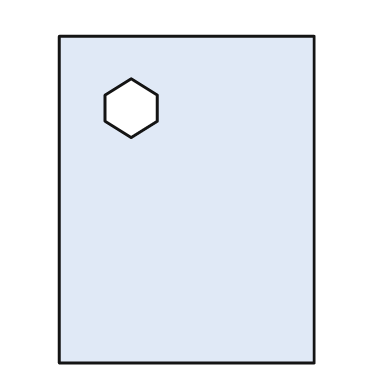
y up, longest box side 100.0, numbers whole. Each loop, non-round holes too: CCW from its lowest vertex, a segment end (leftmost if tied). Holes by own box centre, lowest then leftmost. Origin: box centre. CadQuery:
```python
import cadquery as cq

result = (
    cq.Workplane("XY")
    .moveTo(-39.0, -50.0)
    .lineTo(39.0, -50.0)
    .lineTo(39.0, 50.0)
    .lineTo(-39.0, 50.0)
    .close()
    .moveTo(-17.0, 19.0)
    .lineTo(-9.0, 24.0)
    .lineTo(-9.0, 32.0)
    .lineTo(-17.0, 37.0)
    .lineTo(-25.0, 32.0)
    .lineTo(-25.0, 24.0)
    .close()
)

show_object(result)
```